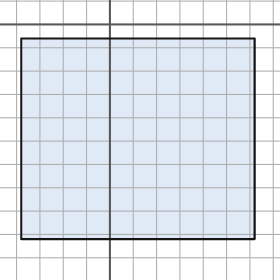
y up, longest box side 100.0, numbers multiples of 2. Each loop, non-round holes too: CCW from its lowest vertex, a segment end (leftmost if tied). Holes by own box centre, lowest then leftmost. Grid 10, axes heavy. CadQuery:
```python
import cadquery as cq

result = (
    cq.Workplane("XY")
    .moveTo(-38.0, -92.0)
    .lineTo(62.0, -92.0)
    .lineTo(62.0, -6.0)
    .lineTo(-38.0, -6.0)
    .close()
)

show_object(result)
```